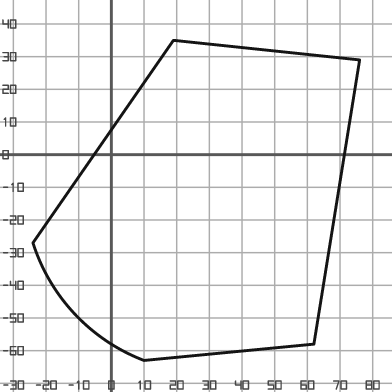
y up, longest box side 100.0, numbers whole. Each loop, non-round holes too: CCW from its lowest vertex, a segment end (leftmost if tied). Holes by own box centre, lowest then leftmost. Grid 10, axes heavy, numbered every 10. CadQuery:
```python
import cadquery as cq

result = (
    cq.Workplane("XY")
    .moveTo(10.0, -63.0)
    .lineTo(62.0, -58.0)
    .lineTo(76.0, 29.0)
    .lineTo(19.0, 35.0)
    .lineTo(-24.0, -27.0)
    .threePointArc((-11.0, -49.0), (10.0, -63.0))
    .close()
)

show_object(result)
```